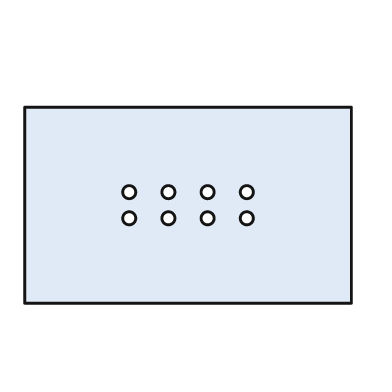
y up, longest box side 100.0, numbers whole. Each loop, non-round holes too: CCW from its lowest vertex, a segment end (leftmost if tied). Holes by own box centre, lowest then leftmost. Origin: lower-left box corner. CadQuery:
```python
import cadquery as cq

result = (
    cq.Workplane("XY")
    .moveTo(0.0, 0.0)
    .lineTo(100.0, 0.0)
    .lineTo(100.0, 60.0)
    .lineTo(0.0, 60.0)
    .close()
    .moveTo(32.0, 26.0)
    .circle(2.0)
    .moveTo(44.0, 26.0)
    .circle(2.0)
    .moveTo(56.0, 26.0)
    .circle(2.0)
    .moveTo(68.0, 26.0)
    .circle(2.0)
    .moveTo(32.0, 34.0)
    .circle(2.0)
    .moveTo(44.0, 34.0)
    .circle(2.0)
    .moveTo(56.0, 34.0)
    .circle(2.0)
    .moveTo(68.0, 34.0)
    .circle(2.0)
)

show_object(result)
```